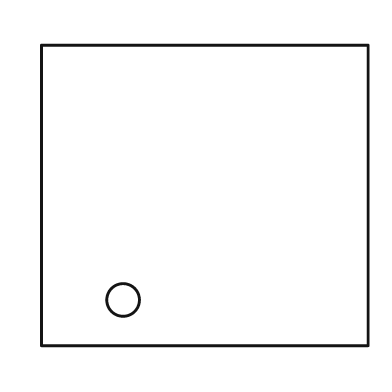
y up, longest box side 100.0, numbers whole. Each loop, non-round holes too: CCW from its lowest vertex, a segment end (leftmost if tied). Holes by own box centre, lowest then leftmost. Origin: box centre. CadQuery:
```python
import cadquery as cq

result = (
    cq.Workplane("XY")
    .moveTo(-50.0, -46.0)
    .lineTo(50.0, -46.0)
    .lineTo(50.0, 46.0)
    .lineTo(-50.0, 46.0)
    .close()
    .moveTo(-25.0, -32.0)
    .circle(5.0)
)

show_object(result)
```